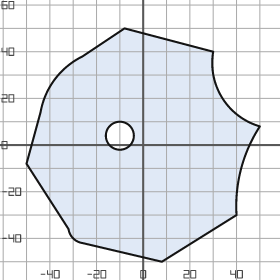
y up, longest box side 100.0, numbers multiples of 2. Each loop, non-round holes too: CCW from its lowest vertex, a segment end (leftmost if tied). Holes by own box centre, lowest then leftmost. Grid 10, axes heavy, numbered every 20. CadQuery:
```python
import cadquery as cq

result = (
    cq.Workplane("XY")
    .moveTo(8.0, -50.0)
    .lineTo(40.0, -30.0)
    .threePointArc((42.0, -10.0), (50.0, 8.0))
    .threePointArc((34.0, 20.0), (30.0, 40.0))
    .lineTo(-8.0, 50.0)
    .lineTo(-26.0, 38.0)
    .threePointArc((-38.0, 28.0), (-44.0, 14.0))
    .lineTo(-50.0, -8.0)
    .lineTo(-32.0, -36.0)
    .threePointArc((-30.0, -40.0), (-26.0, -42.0))
    .close()
    .moveTo(-10.0, 4.0)
    .circle(6.0)
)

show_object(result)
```